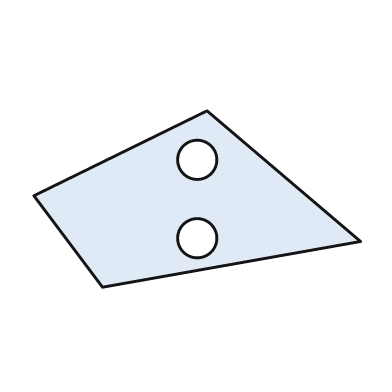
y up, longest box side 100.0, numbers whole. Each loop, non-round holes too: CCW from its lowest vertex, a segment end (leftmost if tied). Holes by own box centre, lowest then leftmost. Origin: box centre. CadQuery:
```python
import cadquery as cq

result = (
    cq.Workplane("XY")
    .moveTo(-29.0, -27.0)
    .lineTo(50.0, -13.0)
    .lineTo(3.0, 27.0)
    .lineTo(-50.0, 1.0)
    .close()
    .moveTo(0.0, -12.0)
    .circle(6.0)
    .moveTo(0.0, 12.0)
    .circle(6.0)
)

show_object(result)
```